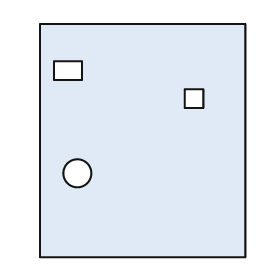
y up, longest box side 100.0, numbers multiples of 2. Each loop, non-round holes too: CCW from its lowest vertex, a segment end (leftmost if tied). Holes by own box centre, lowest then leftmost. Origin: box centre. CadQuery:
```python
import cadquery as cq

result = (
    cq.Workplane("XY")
    .moveTo(-44.0, -50.0)
    .lineTo(44.0, -50.0)
    .lineTo(44.0, 50.0)
    .lineTo(-44.0, 50.0)
    .close()
    .moveTo(-28.0, -14.0)
    .circle(6.0)
    .moveTo(18.0, 14.0)
    .lineTo(26.0, 14.0)
    .lineTo(26.0, 22.0)
    .lineTo(18.0, 22.0)
    .close()
    .moveTo(-38.0, 26.0)
    .lineTo(-26.0, 26.0)
    .lineTo(-26.0, 34.0)
    .lineTo(-38.0, 34.0)
    .close()
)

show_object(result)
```